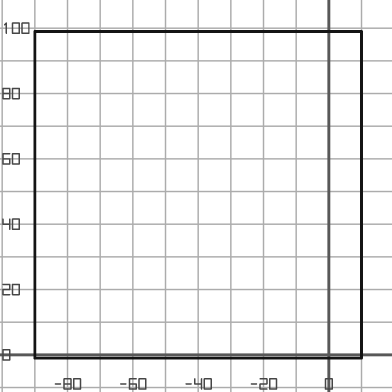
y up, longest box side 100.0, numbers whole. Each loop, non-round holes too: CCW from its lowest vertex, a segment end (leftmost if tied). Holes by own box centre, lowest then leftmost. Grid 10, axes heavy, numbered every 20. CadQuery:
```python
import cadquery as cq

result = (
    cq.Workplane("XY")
    .moveTo(-90.0, -1.0)
    .lineTo(10.0, -1.0)
    .lineTo(10.0, 99.0)
    .lineTo(-90.0, 99.0)
    .close()
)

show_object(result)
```